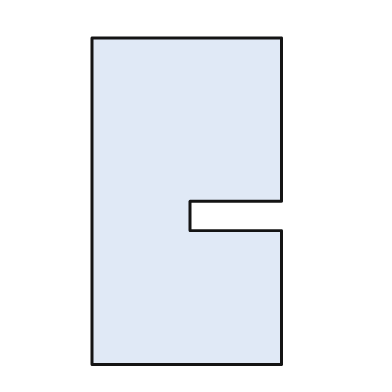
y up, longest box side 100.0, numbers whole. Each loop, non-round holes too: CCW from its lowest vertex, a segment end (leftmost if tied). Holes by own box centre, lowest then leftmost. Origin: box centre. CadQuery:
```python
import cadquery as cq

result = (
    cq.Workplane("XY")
    .moveTo(-29.0, -50.0)
    .lineTo(29.0, -50.0)
    .lineTo(29.0, -9.0)
    .lineTo(1.0, -9.0)
    .lineTo(1.0, 0.0)
    .lineTo(29.0, 0.0)
    .lineTo(29.0, 50.0)
    .lineTo(-29.0, 50.0)
    .close()
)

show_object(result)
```